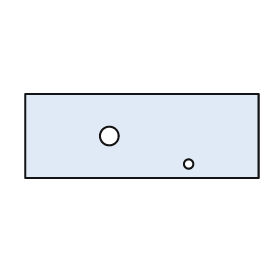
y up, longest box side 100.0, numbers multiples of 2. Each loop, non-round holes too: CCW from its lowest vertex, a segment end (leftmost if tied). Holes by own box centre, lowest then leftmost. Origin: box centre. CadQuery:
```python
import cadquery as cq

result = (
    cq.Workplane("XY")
    .moveTo(-50.0, -18.0)
    .lineTo(50.0, -18.0)
    .lineTo(50.0, 18.0)
    .lineTo(-50.0, 18.0)
    .close()
    .moveTo(20.0, -12.0)
    .circle(2.0)
    .moveTo(-14.0, 0.0)
    .circle(4.0)
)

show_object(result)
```